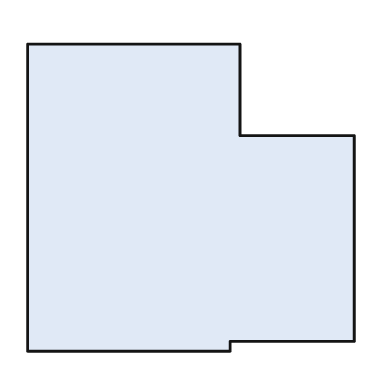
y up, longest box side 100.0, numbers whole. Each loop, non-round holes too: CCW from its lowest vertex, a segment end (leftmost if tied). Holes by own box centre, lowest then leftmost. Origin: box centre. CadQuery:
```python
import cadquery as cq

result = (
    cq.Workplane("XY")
    .moveTo(-50.0, -47.0)
    .lineTo(12.0, -47.0)
    .lineTo(12.0, -44.0)
    .lineTo(50.0, -44.0)
    .lineTo(50.0, 19.0)
    .lineTo(15.0, 19.0)
    .lineTo(15.0, 47.0)
    .lineTo(-50.0, 47.0)
    .close()
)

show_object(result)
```